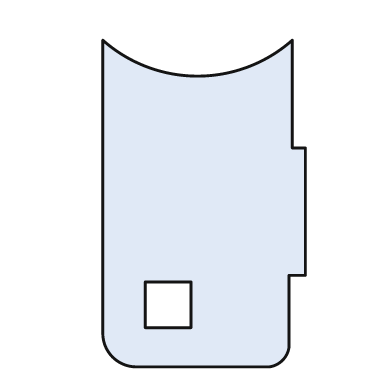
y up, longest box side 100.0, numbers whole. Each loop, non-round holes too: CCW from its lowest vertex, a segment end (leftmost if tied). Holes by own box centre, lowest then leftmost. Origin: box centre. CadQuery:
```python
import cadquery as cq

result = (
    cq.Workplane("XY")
    .moveTo(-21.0, -50.0)
    .lineTo(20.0, -50.0)
    .threePointArc((24.0, -48.0), (26.0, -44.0))
    .lineTo(26.0, -22.0)
    .lineTo(31.0, -22.0)
    .lineTo(31.0, 17.0)
    .lineTo(27.0, 17.0)
    .lineTo(27.0, 50.0)
    .threePointArc((-2.0, 39.0), (-31.0, 50.0))
    .lineTo(-31.0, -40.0)
    .threePointArc((-28.0, -47.0), (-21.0, -50.0))
    .close()
    .moveTo(-18.0, -38.0)
    .lineTo(-4.0, -38.0)
    .lineTo(-4.0, -24.0)
    .lineTo(-18.0, -24.0)
    .close()
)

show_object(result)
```